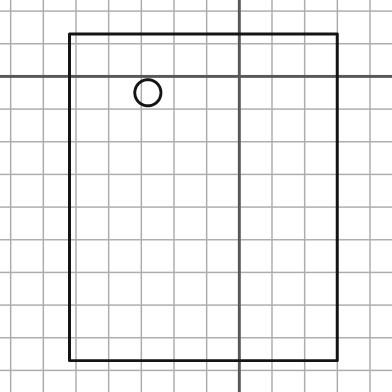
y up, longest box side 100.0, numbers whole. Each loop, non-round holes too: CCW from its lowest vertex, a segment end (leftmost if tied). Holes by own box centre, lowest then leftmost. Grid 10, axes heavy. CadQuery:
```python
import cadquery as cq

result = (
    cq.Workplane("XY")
    .moveTo(-52.0, -87.0)
    .lineTo(30.0, -87.0)
    .lineTo(30.0, 13.0)
    .lineTo(-52.0, 13.0)
    .close()
    .moveTo(-28.0, -5.0)
    .circle(4.0)
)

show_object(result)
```